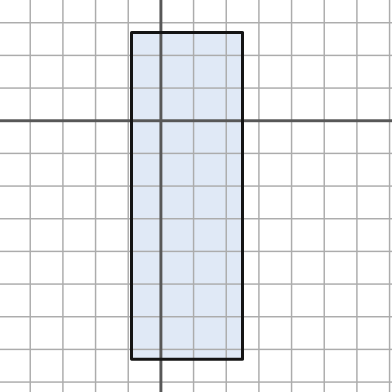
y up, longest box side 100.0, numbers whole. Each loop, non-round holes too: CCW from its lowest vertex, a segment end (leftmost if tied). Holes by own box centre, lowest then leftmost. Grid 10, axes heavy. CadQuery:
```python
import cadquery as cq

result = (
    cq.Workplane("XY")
    .moveTo(-9.0, -73.0)
    .lineTo(25.0, -73.0)
    .lineTo(25.0, 27.0)
    .lineTo(-9.0, 27.0)
    .close()
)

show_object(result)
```